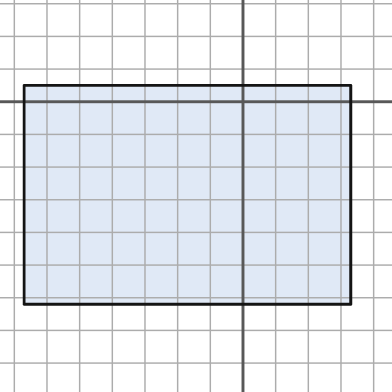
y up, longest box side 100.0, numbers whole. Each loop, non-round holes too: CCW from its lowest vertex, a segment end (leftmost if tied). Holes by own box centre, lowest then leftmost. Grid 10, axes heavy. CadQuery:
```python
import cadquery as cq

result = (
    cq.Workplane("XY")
    .moveTo(-67.0, -62.0)
    .lineTo(33.0, -62.0)
    .lineTo(33.0, 5.0)
    .lineTo(-67.0, 5.0)
    .close()
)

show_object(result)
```